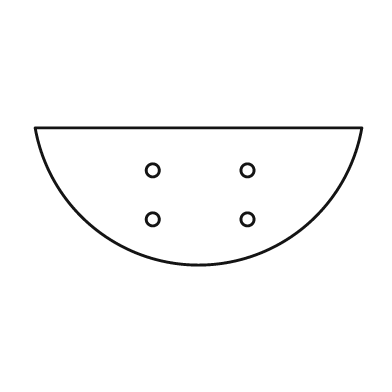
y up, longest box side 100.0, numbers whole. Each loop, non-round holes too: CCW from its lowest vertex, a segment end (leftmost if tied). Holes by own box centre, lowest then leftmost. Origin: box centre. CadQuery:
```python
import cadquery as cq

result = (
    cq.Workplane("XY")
    .moveTo(-50.0, 21.0)
    .threePointArc((0.0, -21.0), (50.0, 21.0))
    .close()
    .moveTo(-14.0, -7.0)
    .circle(2.0)
    .moveTo(15.0, -7.0)
    .circle(2.0)
    .moveTo(-14.0, 8.0)
    .circle(2.0)
    .moveTo(15.0, 8.0)
    .circle(2.0)
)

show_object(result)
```